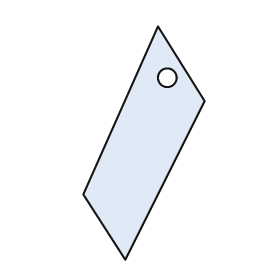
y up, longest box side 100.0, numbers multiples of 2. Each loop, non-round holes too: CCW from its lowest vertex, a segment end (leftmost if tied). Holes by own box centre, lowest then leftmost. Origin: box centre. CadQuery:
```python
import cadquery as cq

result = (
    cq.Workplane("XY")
    .moveTo(-8.0, -50.0)
    .lineTo(26.0, 18.0)
    .lineTo(6.0, 50.0)
    .lineTo(-26.0, -22.0)
    .close()
    .moveTo(10.0, 28.0)
    .circle(4.0)
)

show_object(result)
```